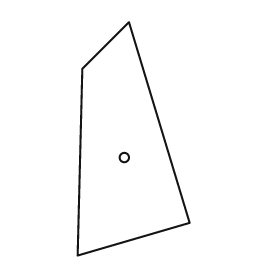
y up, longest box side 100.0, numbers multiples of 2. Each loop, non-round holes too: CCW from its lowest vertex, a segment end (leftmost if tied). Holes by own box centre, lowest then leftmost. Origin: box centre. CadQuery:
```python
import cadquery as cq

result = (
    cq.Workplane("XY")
    .moveTo(-24.0, -50.0)
    .lineTo(24.0, -36.0)
    .lineTo(-2.0, 50.0)
    .lineTo(-22.0, 30.0)
    .close()
    .moveTo(-4.0, -8.0)
    .circle(2.0)
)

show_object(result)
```